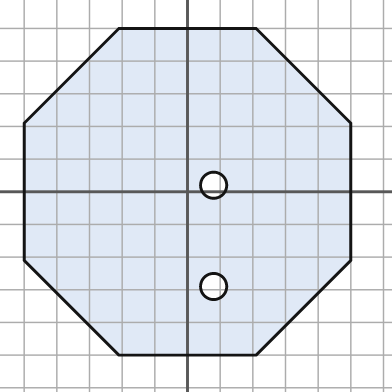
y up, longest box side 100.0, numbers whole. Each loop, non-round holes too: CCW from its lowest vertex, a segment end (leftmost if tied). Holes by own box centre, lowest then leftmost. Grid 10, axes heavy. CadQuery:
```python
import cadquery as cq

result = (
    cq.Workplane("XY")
    .moveTo(-21.0, -50.0)
    .lineTo(21.0, -50.0)
    .lineTo(50.0, -21.0)
    .lineTo(50.0, 21.0)
    .lineTo(21.0, 50.0)
    .lineTo(-21.0, 50.0)
    .lineTo(-50.0, 21.0)
    .lineTo(-50.0, -21.0)
    .close()
    .moveTo(8.0, -29.0)
    .circle(4.0)
    .moveTo(8.0, 2.0)
    .circle(4.0)
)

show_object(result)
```